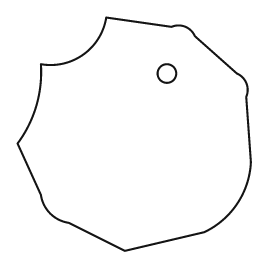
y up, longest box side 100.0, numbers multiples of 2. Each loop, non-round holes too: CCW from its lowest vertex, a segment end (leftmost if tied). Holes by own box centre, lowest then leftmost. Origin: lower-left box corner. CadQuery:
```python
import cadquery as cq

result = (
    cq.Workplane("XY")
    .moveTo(46.0, 0.0)
    .lineTo(80.0, 8.0)
    .threePointArc((94.0, 20.0), (100.0, 38.0))
    .lineTo(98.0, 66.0)
    .threePointArc((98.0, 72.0), (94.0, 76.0))
    .lineTo(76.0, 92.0)
    .threePointArc((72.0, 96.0), (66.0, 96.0))
    .lineTo(38.0, 100.0)
    .threePointArc((28.0, 84.0), (10.0, 80.0))
    .threePointArc((8.0, 62.0), (0.0, 46.0))
    .lineTo(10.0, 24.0)
    .threePointArc((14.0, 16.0), (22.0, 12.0))
    .close()
    .moveTo(64.0, 76.0)
    .circle(4.0)
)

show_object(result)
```